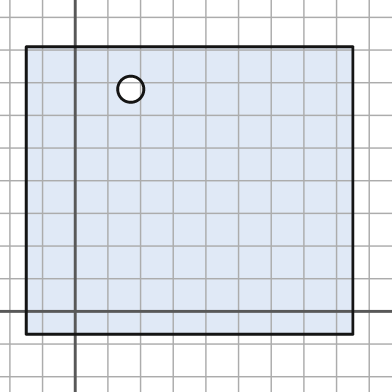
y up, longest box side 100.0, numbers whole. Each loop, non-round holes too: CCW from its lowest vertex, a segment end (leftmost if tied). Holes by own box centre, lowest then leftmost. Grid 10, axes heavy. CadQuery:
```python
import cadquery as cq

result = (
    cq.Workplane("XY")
    .moveTo(-15.0, -7.0)
    .lineTo(85.0, -7.0)
    .lineTo(85.0, 81.0)
    .lineTo(-15.0, 81.0)
    .close()
    .moveTo(17.0, 68.0)
    .circle(4.0)
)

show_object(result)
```